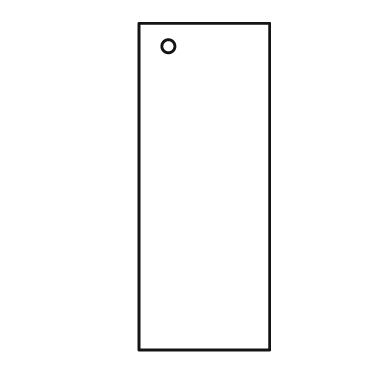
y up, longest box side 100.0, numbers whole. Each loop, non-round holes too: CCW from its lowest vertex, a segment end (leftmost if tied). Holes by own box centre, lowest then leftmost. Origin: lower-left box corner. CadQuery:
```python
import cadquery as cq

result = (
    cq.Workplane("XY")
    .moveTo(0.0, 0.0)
    .lineTo(40.0, 0.0)
    .lineTo(40.0, 100.0)
    .lineTo(0.0, 100.0)
    .close()
    .moveTo(9.0, 93.0)
    .circle(2.0)
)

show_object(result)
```